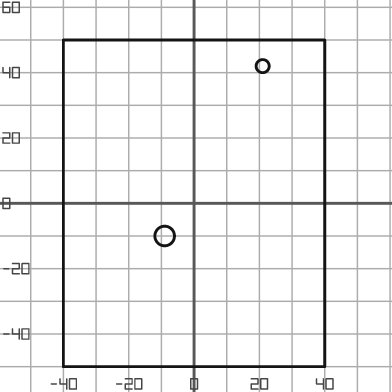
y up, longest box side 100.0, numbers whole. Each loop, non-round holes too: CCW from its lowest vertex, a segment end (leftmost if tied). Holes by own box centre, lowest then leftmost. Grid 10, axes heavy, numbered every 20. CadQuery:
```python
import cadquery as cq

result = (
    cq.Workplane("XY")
    .moveTo(-40.0, -50.0)
    .lineTo(40.0, -50.0)
    .lineTo(40.0, 50.0)
    .lineTo(-40.0, 50.0)
    .close()
    .moveTo(-9.0, -10.0)
    .circle(3.0)
    .moveTo(21.0, 42.0)
    .circle(2.0)
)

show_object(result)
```